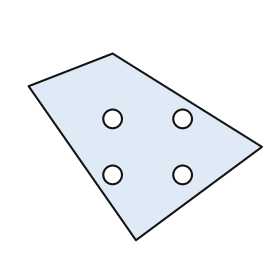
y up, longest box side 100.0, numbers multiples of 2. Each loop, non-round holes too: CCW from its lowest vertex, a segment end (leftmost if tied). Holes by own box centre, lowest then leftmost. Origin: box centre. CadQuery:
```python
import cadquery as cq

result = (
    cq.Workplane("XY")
    .moveTo(-4.0, -40.0)
    .lineTo(50.0, 0.0)
    .lineTo(-14.0, 40.0)
    .lineTo(-50.0, 26.0)
    .close()
    .moveTo(-14.0, -12.0)
    .circle(4.0)
    .moveTo(16.0, -12.0)
    .circle(4.0)
    .moveTo(-14.0, 12.0)
    .circle(4.0)
    .moveTo(16.0, 12.0)
    .circle(4.0)
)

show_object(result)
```